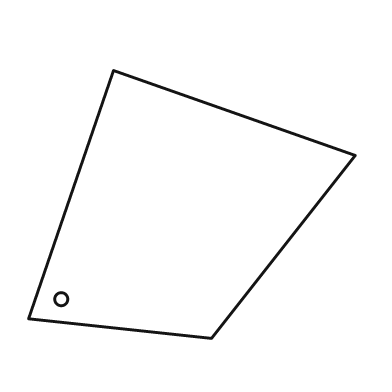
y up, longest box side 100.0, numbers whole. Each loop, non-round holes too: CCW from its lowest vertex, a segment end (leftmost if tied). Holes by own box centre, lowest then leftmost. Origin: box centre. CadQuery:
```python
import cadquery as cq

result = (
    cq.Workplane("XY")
    .moveTo(6.0, -41.0)
    .lineTo(50.0, 15.0)
    .lineTo(-24.0, 41.0)
    .lineTo(-50.0, -35.0)
    .close()
    .moveTo(-40.0, -29.0)
    .circle(2.0)
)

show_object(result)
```